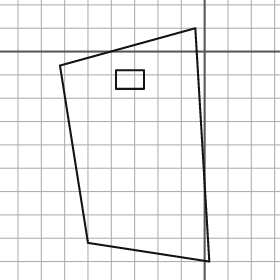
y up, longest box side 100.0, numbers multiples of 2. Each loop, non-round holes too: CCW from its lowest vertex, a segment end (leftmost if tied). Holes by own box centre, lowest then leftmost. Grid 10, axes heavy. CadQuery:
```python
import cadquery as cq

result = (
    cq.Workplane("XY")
    .moveTo(2.0, -90.0)
    .lineTo(-4.0, 10.0)
    .lineTo(-62.0, -6.0)
    .lineTo(-50.0, -82.0)
    .close()
    .moveTo(-38.0, -16.0)
    .lineTo(-26.0, -16.0)
    .lineTo(-26.0, -8.0)
    .lineTo(-38.0, -8.0)
    .close()
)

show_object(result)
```